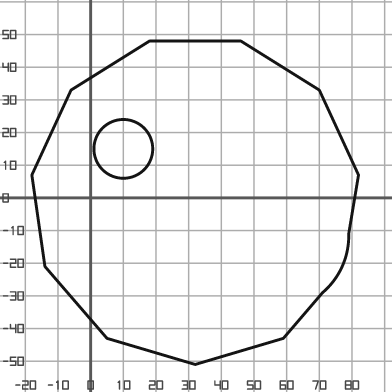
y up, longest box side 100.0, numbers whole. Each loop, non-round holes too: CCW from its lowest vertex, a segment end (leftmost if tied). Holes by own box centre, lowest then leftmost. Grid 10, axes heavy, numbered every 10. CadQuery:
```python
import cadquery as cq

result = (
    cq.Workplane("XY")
    .moveTo(32.0, -51.0)
    .lineTo(59.0, -43.0)
    .lineTo(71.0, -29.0)
    .threePointArc((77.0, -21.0), (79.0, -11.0))
    .lineTo(82.0, 7.0)
    .lineTo(70.0, 33.0)
    .lineTo(46.0, 48.0)
    .lineTo(18.0, 48.0)
    .lineTo(-6.0, 33.0)
    .lineTo(-18.0, 7.0)
    .lineTo(-14.0, -21.0)
    .lineTo(5.0, -43.0)
    .close()
    .moveTo(10.0, 15.0)
    .circle(9.0)
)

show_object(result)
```